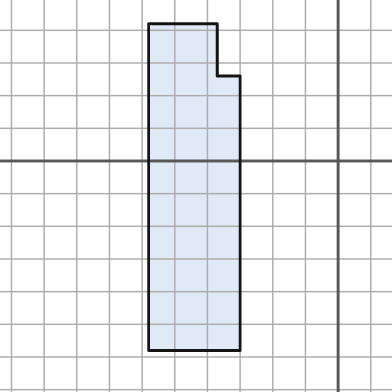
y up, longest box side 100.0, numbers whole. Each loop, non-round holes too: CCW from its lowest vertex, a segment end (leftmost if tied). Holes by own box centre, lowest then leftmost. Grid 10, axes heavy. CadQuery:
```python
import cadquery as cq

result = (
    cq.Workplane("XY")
    .moveTo(-58.0, -58.0)
    .lineTo(-30.0, -58.0)
    .lineTo(-30.0, 26.0)
    .lineTo(-37.0, 26.0)
    .lineTo(-37.0, 42.0)
    .lineTo(-58.0, 42.0)
    .close()
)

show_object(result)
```